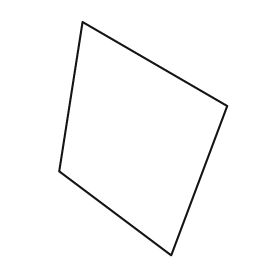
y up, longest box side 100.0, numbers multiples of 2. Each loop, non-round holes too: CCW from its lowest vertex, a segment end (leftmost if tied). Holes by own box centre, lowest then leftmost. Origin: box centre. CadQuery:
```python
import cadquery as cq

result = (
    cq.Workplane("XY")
    .moveTo(12.0, -50.0)
    .lineTo(36.0, 14.0)
    .lineTo(-26.0, 50.0)
    .lineTo(-36.0, -14.0)
    .close()
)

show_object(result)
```